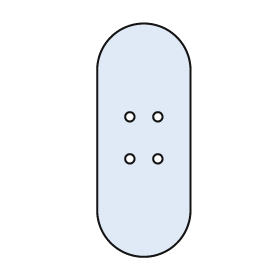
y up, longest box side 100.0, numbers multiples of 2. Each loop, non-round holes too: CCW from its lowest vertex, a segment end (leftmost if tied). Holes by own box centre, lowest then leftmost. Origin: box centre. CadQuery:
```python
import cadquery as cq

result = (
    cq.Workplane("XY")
    .moveTo(-20.0, -30.0)
    .threePointArc((0.0, -50.0), (20.0, -30.0))
    .lineTo(20.0, 30.0)
    .threePointArc((0.0, 50.0), (-20.0, 30.0))
    .close()
    .moveTo(-6.0, -8.0)
    .circle(2.0)
    .moveTo(6.0, -8.0)
    .circle(2.0)
    .moveTo(-6.0, 10.0)
    .circle(2.0)
    .moveTo(6.0, 10.0)
    .circle(2.0)
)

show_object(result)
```